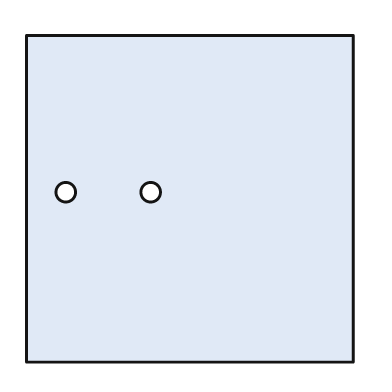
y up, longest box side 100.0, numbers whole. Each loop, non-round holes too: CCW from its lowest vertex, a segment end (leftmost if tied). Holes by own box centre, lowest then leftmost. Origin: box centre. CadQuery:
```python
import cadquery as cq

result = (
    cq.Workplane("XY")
    .moveTo(-50.0, -50.0)
    .lineTo(50.0, -50.0)
    .lineTo(50.0, 50.0)
    .lineTo(-50.0, 50.0)
    .close()
    .moveTo(-38.0, 2.0)
    .circle(3.0)
    .moveTo(-12.0, 2.0)
    .circle(3.0)
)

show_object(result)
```